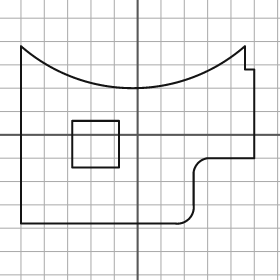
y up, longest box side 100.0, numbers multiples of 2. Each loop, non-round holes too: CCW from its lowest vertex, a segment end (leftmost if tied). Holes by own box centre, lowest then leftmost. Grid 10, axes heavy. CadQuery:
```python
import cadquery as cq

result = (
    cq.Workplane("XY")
    .moveTo(-50.0, -38.0)
    .lineTo(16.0, -38.0)
    .threePointArc((22.0, -36.0), (24.0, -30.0))
    .lineTo(24.0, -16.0)
    .threePointArc((26.0, -12.0), (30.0, -10.0))
    .lineTo(50.0, -10.0)
    .lineTo(50.0, 28.0)
    .lineTo(46.0, 28.0)
    .lineTo(46.0, 38.0)
    .threePointArc((-2.0, 20.0), (-50.0, 38.0))
    .close()
    .moveTo(-28.0, -14.0)
    .lineTo(-8.0, -14.0)
    .lineTo(-8.0, 6.0)
    .lineTo(-28.0, 6.0)
    .close()
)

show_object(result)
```